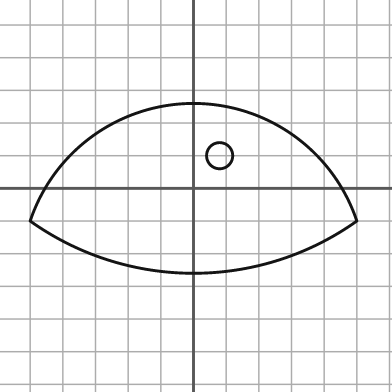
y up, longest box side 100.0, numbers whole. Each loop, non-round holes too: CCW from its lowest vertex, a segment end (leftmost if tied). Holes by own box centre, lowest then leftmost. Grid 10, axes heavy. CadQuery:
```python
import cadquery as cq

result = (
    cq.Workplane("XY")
    .moveTo(-50.0, -10.0)
    .threePointArc((0.0, -26.0), (50.0, -10.0))
    .threePointArc((0.0, 26.0), (-50.0, -10.0))
    .close()
    .moveTo(8.0, 10.0)
    .circle(4.0)
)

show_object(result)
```